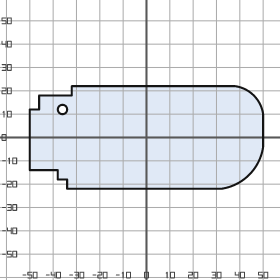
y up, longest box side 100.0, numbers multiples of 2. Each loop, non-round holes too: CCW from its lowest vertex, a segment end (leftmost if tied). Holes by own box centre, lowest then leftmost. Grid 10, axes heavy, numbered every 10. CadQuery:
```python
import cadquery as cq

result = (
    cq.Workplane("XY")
    .moveTo(-34.0, -22.0)
    .lineTo(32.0, -22.0)
    .threePointArc((44.0, -16.0), (50.0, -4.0))
    .lineTo(50.0, 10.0)
    .threePointArc((46.0, 18.0), (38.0, 22.0))
    .lineTo(-32.0, 22.0)
    .lineTo(-32.0, 18.0)
    .lineTo(-46.0, 18.0)
    .lineTo(-46.0, 12.0)
    .lineTo(-50.0, 12.0)
    .lineTo(-50.0, -14.0)
    .lineTo(-38.0, -14.0)
    .lineTo(-38.0, -18.0)
    .lineTo(-34.0, -18.0)
    .close()
    .moveTo(-36.0, 12.0)
    .circle(2.0)
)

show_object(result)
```